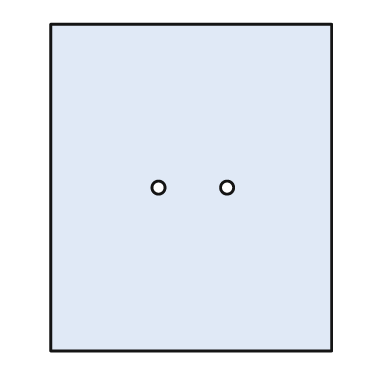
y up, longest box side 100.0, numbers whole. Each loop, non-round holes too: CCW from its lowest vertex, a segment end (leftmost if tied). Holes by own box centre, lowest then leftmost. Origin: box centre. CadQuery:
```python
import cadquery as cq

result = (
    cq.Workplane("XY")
    .moveTo(-43.0, -50.0)
    .lineTo(43.0, -50.0)
    .lineTo(43.0, 50.0)
    .lineTo(-43.0, 50.0)
    .close()
    .moveTo(-10.0, 0.0)
    .circle(2.0)
    .moveTo(11.0, 0.0)
    .circle(2.0)
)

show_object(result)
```